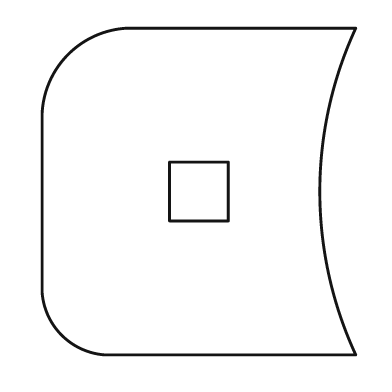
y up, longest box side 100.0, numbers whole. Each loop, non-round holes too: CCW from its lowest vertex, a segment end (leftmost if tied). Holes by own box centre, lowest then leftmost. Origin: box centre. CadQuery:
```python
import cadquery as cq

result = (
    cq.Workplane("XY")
    .moveTo(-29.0, -50.0)
    .lineTo(48.0, -50.0)
    .threePointArc((37.0, 0.0), (48.0, 50.0))
    .lineTo(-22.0, 50.0)
    .threePointArc((-40.0, 42.0), (-48.0, 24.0))
    .lineTo(-48.0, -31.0)
    .threePointArc((-42.0, -44.0), (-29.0, -50.0))
    .close()
    .moveTo(-9.0, -9.0)
    .lineTo(9.0, -9.0)
    .lineTo(9.0, 9.0)
    .lineTo(-9.0, 9.0)
    .close()
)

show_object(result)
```